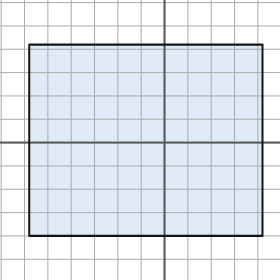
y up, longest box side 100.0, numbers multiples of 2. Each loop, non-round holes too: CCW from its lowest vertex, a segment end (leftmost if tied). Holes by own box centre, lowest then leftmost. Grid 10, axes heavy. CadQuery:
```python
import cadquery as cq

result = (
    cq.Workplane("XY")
    .moveTo(-58.0, -40.0)
    .lineTo(42.0, -40.0)
    .lineTo(42.0, 42.0)
    .lineTo(-58.0, 42.0)
    .close()
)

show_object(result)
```